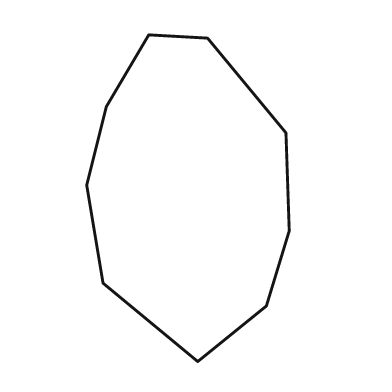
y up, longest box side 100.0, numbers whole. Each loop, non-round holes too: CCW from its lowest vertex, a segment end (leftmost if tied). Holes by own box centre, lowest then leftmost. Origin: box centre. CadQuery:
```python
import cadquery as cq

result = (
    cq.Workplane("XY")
    .moveTo(3.0, -50.0)
    .lineTo(24.0, -33.0)
    .lineTo(31.0, -10.0)
    .lineTo(30.0, 20.0)
    .lineTo(6.0, 49.0)
    .lineTo(-12.0, 50.0)
    .lineTo(-25.0, 28.0)
    .lineTo(-31.0, 4.0)
    .lineTo(-26.0, -26.0)
    .close()
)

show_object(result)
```